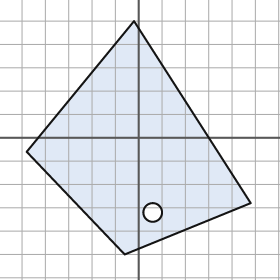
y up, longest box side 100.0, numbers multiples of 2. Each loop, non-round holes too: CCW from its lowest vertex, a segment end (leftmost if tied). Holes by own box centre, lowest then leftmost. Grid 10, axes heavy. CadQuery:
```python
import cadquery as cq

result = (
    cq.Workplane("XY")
    .moveTo(-6.0, -50.0)
    .lineTo(48.0, -28.0)
    .lineTo(-2.0, 50.0)
    .lineTo(-48.0, -6.0)
    .close()
    .moveTo(6.0, -32.0)
    .circle(4.0)
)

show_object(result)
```